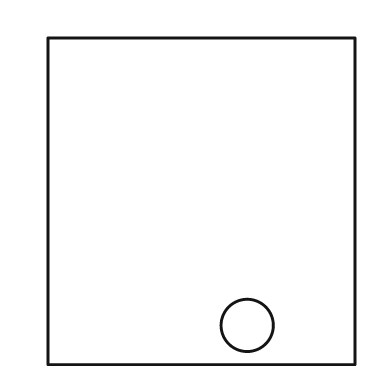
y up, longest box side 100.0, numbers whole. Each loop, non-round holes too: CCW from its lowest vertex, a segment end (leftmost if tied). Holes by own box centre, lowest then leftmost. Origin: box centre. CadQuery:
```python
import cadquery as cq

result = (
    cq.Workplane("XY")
    .moveTo(-47.0, -50.0)
    .lineTo(47.0, -50.0)
    .lineTo(47.0, 50.0)
    .lineTo(-47.0, 50.0)
    .close()
    .moveTo(14.0, -38.0)
    .circle(8.0)
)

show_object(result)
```